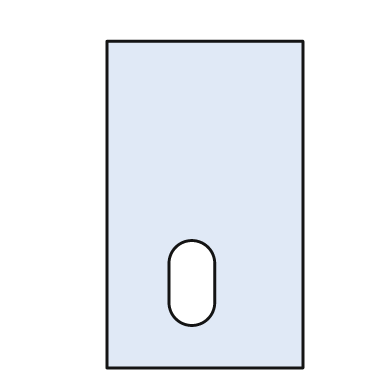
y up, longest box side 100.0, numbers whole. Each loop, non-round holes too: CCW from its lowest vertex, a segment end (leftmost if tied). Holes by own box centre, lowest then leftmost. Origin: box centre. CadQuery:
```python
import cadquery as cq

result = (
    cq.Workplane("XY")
    .moveTo(-30.0, -50.0)
    .lineTo(30.0, -50.0)
    .lineTo(30.0, 50.0)
    .lineTo(-30.0, 50.0)
    .close()
    .moveTo(-11.0, -30.0)
    .threePointArc((-4.0, -37.0), (3.0, -30.0))
    .lineTo(3.0, -18.0)
    .threePointArc((-4.0, -11.0), (-11.0, -18.0))
    .close()
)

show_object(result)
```